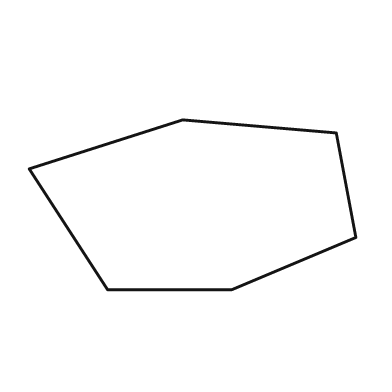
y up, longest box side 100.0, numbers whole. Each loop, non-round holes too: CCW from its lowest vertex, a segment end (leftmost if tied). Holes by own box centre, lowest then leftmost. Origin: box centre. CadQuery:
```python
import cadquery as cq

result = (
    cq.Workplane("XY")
    .moveTo(-26.0, -26.0)
    .lineTo(12.0, -26.0)
    .lineTo(50.0, -10.0)
    .lineTo(44.0, 22.0)
    .lineTo(-3.0, 26.0)
    .lineTo(-50.0, 11.0)
    .close()
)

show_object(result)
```